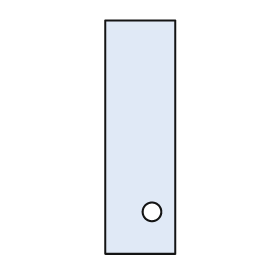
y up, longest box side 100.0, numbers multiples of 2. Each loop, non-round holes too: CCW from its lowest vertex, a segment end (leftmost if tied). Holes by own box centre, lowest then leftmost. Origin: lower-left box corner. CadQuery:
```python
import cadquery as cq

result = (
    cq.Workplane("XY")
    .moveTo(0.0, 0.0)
    .lineTo(30.0, 0.0)
    .lineTo(30.0, 100.0)
    .lineTo(0.0, 100.0)
    .close()
    .moveTo(20.0, 18.0)
    .circle(4.0)
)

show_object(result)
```